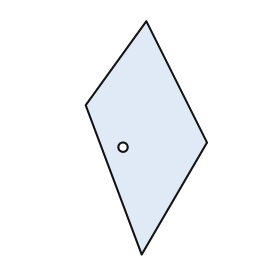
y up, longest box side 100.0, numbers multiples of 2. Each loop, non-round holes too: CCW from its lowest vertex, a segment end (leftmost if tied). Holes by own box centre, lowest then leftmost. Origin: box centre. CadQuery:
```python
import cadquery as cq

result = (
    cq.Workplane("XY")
    .moveTo(-2.0, -50.0)
    .lineTo(26.0, -2.0)
    .lineTo(0.0, 50.0)
    .lineTo(-26.0, 14.0)
    .close()
    .moveTo(-10.0, -4.0)
    .circle(2.0)
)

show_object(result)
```